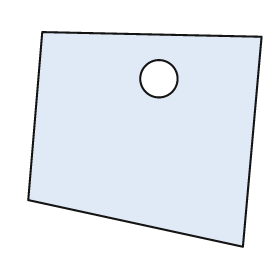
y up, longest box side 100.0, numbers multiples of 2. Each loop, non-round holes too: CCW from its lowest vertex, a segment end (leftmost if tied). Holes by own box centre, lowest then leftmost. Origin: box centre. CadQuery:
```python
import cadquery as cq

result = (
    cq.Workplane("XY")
    .moveTo(42.0, -46.0)
    .lineTo(50.0, 44.0)
    .lineTo(-44.0, 46.0)
    .lineTo(-50.0, -26.0)
    .close()
    .moveTo(6.0, 26.0)
    .circle(8.0)
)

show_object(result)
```